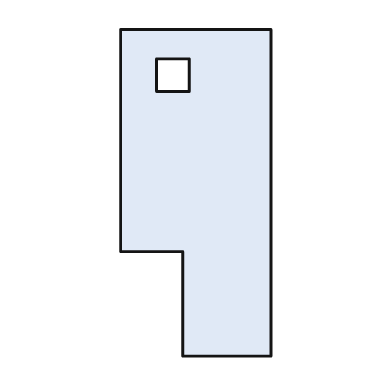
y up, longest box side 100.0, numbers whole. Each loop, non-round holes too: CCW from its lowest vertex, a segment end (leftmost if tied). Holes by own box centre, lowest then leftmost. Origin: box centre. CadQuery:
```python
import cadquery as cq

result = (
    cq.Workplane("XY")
    .moveTo(-4.0, -50.0)
    .lineTo(23.0, -50.0)
    .lineTo(23.0, 50.0)
    .lineTo(-23.0, 50.0)
    .lineTo(-23.0, -18.0)
    .lineTo(-4.0, -18.0)
    .close()
    .moveTo(-12.0, 31.0)
    .lineTo(-2.0, 31.0)
    .lineTo(-2.0, 41.0)
    .lineTo(-12.0, 41.0)
    .close()
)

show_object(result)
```